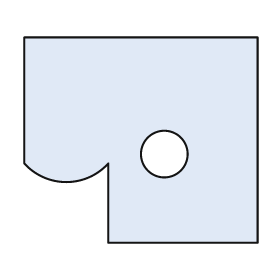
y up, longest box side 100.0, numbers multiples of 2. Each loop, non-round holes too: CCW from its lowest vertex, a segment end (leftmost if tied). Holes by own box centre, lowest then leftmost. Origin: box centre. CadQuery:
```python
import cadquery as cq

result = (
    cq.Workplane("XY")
    .moveTo(-14.0, -44.0)
    .lineTo(50.0, -44.0)
    .lineTo(50.0, 44.0)
    .lineTo(-50.0, 44.0)
    .lineTo(-50.0, -10.0)
    .threePointArc((-32.0, -18.0), (-14.0, -10.0))
    .close()
    .moveTo(10.0, -6.0)
    .circle(10.0)
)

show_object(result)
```